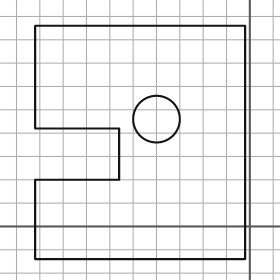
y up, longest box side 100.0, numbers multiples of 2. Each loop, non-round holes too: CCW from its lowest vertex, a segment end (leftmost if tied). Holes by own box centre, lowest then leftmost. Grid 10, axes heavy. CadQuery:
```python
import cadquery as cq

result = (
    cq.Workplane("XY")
    .moveTo(-92.0, -14.0)
    .lineTo(-2.0, -14.0)
    .lineTo(-2.0, 86.0)
    .lineTo(-92.0, 86.0)
    .lineTo(-92.0, 42.0)
    .lineTo(-56.0, 42.0)
    .lineTo(-56.0, 20.0)
    .lineTo(-92.0, 20.0)
    .close()
    .moveTo(-40.0, 46.0)
    .circle(10.0)
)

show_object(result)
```